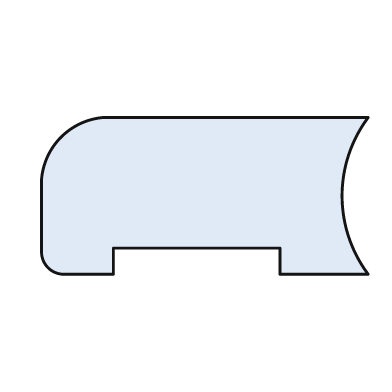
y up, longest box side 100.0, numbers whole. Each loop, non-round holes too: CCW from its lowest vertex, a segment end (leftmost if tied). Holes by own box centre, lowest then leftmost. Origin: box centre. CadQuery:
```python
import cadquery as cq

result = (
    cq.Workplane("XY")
    .moveTo(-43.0, -24.0)
    .lineTo(-28.0, -24.0)
    .lineTo(-28.0, -16.0)
    .lineTo(23.0, -16.0)
    .lineTo(23.0, -24.0)
    .lineTo(50.0, -24.0)
    .threePointArc((42.0, 0.0), (50.0, 24.0))
    .lineTo(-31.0, 24.0)
    .threePointArc((-44.0, 18.0), (-50.0, 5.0))
    .lineTo(-50.0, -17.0)
    .threePointArc((-48.0, -22.0), (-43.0, -24.0))
    .close()
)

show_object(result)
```